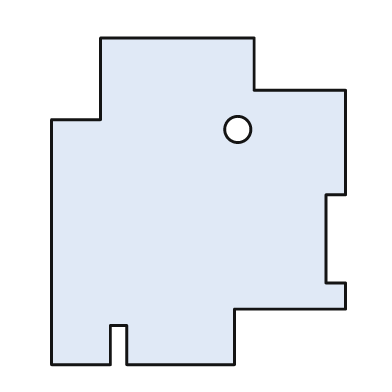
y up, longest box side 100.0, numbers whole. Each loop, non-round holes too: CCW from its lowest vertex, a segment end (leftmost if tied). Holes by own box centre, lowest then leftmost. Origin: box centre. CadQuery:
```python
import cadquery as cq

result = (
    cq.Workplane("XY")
    .moveTo(-45.0, -50.0)
    .lineTo(-27.0, -50.0)
    .lineTo(-27.0, -38.0)
    .lineTo(-22.0, -38.0)
    .lineTo(-22.0, -50.0)
    .lineTo(11.0, -50.0)
    .lineTo(11.0, -33.0)
    .lineTo(45.0, -33.0)
    .lineTo(45.0, -25.0)
    .lineTo(39.0, -25.0)
    .lineTo(39.0, 2.0)
    .lineTo(45.0, 2.0)
    .lineTo(45.0, 34.0)
    .lineTo(17.0, 34.0)
    .lineTo(17.0, 50.0)
    .lineTo(-30.0, 50.0)
    .lineTo(-30.0, 25.0)
    .lineTo(-45.0, 25.0)
    .close()
    .moveTo(12.0, 22.0)
    .circle(4.0)
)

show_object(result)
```